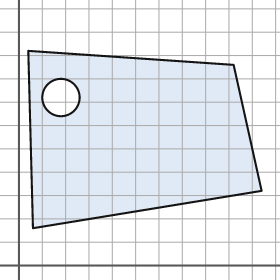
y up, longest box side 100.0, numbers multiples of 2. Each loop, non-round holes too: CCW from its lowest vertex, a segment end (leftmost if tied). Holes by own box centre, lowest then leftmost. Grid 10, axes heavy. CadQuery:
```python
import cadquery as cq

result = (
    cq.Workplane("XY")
    .moveTo(6.0, 16.0)
    .lineTo(104.0, 32.0)
    .lineTo(92.0, 86.0)
    .lineTo(4.0, 92.0)
    .close()
    .moveTo(18.0, 72.0)
    .circle(8.0)
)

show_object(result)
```